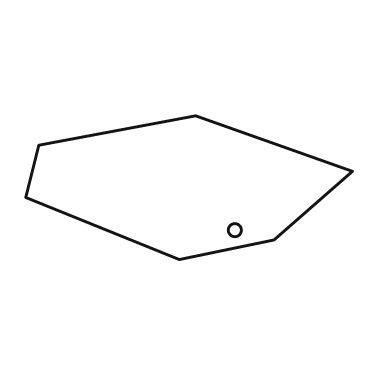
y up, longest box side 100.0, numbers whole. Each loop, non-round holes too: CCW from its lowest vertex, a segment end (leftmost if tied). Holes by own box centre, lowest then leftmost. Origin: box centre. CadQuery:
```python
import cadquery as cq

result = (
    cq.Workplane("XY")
    .moveTo(-3.0, -22.0)
    .lineTo(26.0, -16.0)
    .lineTo(50.0, 5.0)
    .lineTo(2.0, 22.0)
    .lineTo(-46.0, 13.0)
    .lineTo(-50.0, -3.0)
    .close()
    .moveTo(14.0, -13.0)
    .circle(2.0)
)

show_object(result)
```